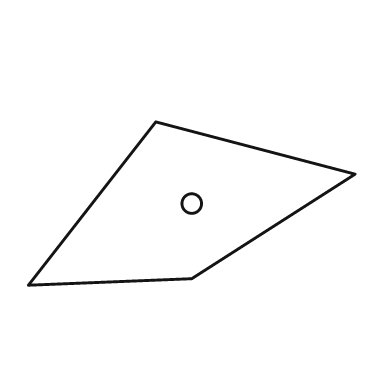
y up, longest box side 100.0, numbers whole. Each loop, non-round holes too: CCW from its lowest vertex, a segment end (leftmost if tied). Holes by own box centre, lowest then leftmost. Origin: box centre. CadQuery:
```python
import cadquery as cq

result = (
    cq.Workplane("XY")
    .moveTo(-50.0, -25.0)
    .lineTo(0.0, -23.0)
    .lineTo(50.0, 9.0)
    .lineTo(-11.0, 25.0)
    .close()
    .moveTo(0.0, 0.0)
    .circle(3.0)
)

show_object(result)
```